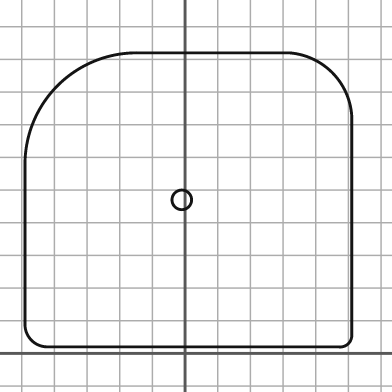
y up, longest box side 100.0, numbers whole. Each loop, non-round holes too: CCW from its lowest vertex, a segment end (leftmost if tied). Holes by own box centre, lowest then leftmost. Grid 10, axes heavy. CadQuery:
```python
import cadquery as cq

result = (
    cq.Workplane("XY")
    .moveTo(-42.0, 2.0)
    .lineTo(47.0, 2.0)
    .threePointArc((50.0, 3.0), (51.0, 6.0))
    .lineTo(51.0, 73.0)
    .threePointArc((45.0, 86.0), (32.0, 92.0))
    .lineTo(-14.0, 92.0)
    .threePointArc((-39.0, 82.0), (-49.0, 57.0))
    .lineTo(-49.0, 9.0)
    .threePointArc((-47.0, 4.0), (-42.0, 2.0))
    .close()
    .moveTo(-1.0, 47.0)
    .circle(3.0)
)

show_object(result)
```